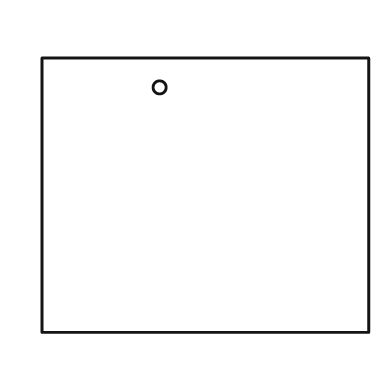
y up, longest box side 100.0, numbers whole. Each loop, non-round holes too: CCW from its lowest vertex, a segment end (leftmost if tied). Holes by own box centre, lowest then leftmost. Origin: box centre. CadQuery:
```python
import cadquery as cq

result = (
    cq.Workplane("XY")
    .moveTo(-50.0, -42.0)
    .lineTo(50.0, -42.0)
    .lineTo(50.0, 42.0)
    .lineTo(-50.0, 42.0)
    .close()
    .moveTo(-14.0, 33.0)
    .circle(2.0)
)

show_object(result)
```